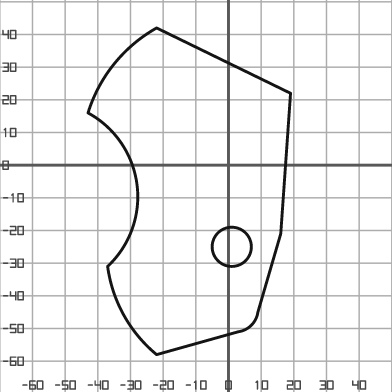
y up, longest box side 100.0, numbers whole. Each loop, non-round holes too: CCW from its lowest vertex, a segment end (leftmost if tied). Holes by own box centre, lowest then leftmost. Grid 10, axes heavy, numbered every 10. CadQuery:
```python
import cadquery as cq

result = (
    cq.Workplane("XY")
    .moveTo(-22.0, -58.0)
    .lineTo(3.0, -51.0)
    .threePointArc((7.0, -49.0), (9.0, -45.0))
    .lineTo(16.0, -21.0)
    .lineTo(19.0, 22.0)
    .lineTo(-22.0, 42.0)
    .threePointArc((-35.0, 31.0), (-43.0, 16.0))
    .threePointArc((-28.0, -6.0), (-37.0, -31.0))
    .threePointArc((-32.0, -46.0), (-22.0, -58.0))
    .close()
    .moveTo(1.0, -25.0)
    .circle(6.0)
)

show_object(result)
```